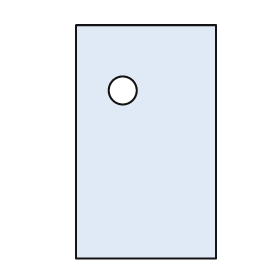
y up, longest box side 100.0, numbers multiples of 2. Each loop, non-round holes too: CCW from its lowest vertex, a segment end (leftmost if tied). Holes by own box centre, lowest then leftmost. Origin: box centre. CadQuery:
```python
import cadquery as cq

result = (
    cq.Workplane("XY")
    .moveTo(-30.0, -50.0)
    .lineTo(30.0, -50.0)
    .lineTo(30.0, 50.0)
    .lineTo(-30.0, 50.0)
    .close()
    .moveTo(-10.0, 22.0)
    .circle(6.0)
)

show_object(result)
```